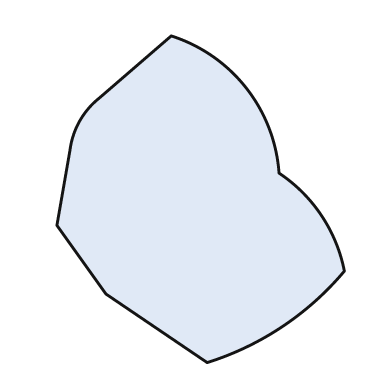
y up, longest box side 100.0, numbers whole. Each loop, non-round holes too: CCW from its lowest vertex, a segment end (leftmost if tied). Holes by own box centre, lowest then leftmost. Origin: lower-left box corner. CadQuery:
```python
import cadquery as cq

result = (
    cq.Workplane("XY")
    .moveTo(46.0, 0.0)
    .threePointArc((69.0, 11.0), (88.0, 28.0))
    .threePointArc((81.0, 45.0), (68.0, 58.0))
    .threePointArc((58.0, 84.0), (35.0, 100.0))
    .lineTo(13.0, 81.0)
    .threePointArc((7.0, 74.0), (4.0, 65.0))
    .lineTo(0.0, 42.0)
    .lineTo(15.0, 21.0)
    .close()
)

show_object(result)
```